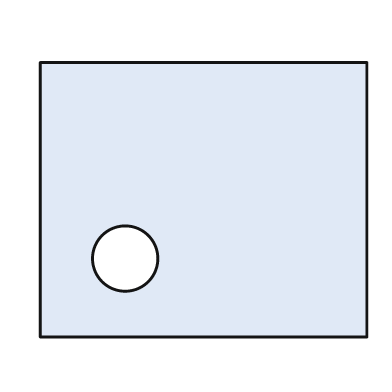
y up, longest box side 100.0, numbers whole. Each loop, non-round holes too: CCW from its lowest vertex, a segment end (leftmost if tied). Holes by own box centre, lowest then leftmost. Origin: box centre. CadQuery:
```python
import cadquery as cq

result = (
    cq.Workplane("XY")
    .moveTo(-50.0, -42.0)
    .lineTo(50.0, -42.0)
    .lineTo(50.0, 42.0)
    .lineTo(-50.0, 42.0)
    .close()
    .moveTo(-24.0, -18.0)
    .circle(10.0)
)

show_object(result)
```